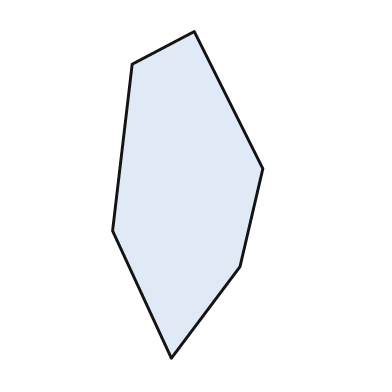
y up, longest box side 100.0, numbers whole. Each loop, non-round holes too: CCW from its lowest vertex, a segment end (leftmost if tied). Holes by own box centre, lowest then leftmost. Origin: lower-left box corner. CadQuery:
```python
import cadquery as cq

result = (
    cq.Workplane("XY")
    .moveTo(18.0, 0.0)
    .lineTo(39.0, 28.0)
    .lineTo(46.0, 58.0)
    .lineTo(25.0, 100.0)
    .lineTo(6.0, 90.0)
    .lineTo(0.0, 39.0)
    .close()
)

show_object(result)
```